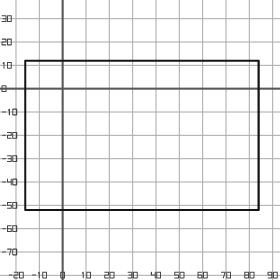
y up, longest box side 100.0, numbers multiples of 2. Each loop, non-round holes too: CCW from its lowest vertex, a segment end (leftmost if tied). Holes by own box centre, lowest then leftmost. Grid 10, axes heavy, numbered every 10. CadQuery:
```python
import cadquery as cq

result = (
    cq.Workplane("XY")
    .moveTo(-16.0, -52.0)
    .lineTo(84.0, -52.0)
    .lineTo(84.0, 12.0)
    .lineTo(-16.0, 12.0)
    .close()
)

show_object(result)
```